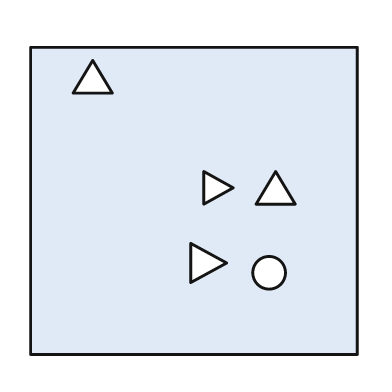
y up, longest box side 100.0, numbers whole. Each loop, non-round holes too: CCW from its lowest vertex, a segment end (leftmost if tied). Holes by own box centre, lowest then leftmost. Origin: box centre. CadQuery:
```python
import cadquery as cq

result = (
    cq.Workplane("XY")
    .moveTo(-50.0, -47.0)
    .lineTo(50.0, -47.0)
    .lineTo(50.0, 47.0)
    .lineTo(-50.0, 47.0)
    .close()
    .moveTo(23.0, -22.0)
    .circle(5.0)
    .moveTo(-1.0, -25.0)
    .lineTo(10.0, -19.0)
    .lineTo(-1.0, -13.0)
    .close()
    .moveTo(3.0, -1.0)
    .lineTo(12.0, 4.0)
    .lineTo(3.0, 9.0)
    .close()
    .moveTo(19.0, -1.0)
    .lineTo(31.0, -1.0)
    .lineTo(25.0, 9.0)
    .close()
    .moveTo(-37.0, 33.0)
    .lineTo(-25.0, 33.0)
    .lineTo(-31.0, 43.0)
    .close()
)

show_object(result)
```